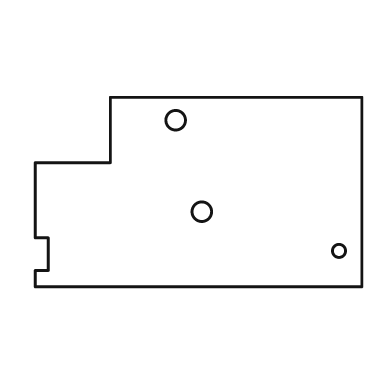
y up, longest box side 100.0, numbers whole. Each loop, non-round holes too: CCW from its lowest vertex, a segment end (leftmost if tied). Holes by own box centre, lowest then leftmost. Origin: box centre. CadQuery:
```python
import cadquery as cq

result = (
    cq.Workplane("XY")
    .moveTo(-50.0, -29.0)
    .lineTo(50.0, -29.0)
    .lineTo(50.0, 29.0)
    .lineTo(-27.0, 29.0)
    .lineTo(-27.0, 9.0)
    .lineTo(-50.0, 9.0)
    .lineTo(-50.0, -14.0)
    .lineTo(-46.0, -14.0)
    .lineTo(-46.0, -24.0)
    .lineTo(-50.0, -24.0)
    .close()
    .moveTo(43.0, -18.0)
    .circle(2.0)
    .moveTo(1.0, -6.0)
    .circle(3.0)
    .moveTo(-7.0, 22.0)
    .circle(3.0)
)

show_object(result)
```